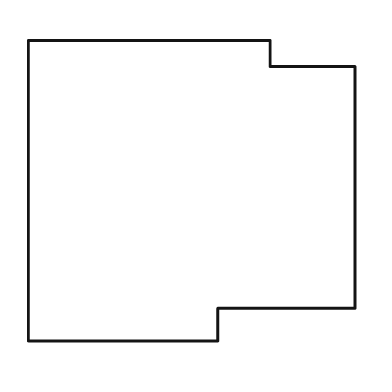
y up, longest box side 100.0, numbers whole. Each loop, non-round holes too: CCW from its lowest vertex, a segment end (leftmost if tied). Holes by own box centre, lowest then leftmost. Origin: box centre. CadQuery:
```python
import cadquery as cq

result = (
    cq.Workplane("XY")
    .moveTo(-50.0, -46.0)
    .lineTo(8.0, -46.0)
    .lineTo(8.0, -36.0)
    .lineTo(50.0, -36.0)
    .lineTo(50.0, 38.0)
    .lineTo(24.0, 38.0)
    .lineTo(24.0, 46.0)
    .lineTo(-50.0, 46.0)
    .close()
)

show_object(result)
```